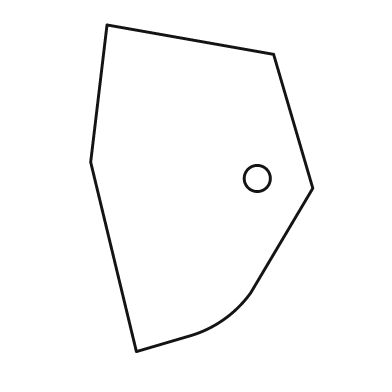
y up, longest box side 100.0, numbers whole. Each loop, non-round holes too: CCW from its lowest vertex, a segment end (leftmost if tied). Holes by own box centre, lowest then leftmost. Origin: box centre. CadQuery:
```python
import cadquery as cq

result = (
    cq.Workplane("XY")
    .moveTo(-20.0, -50.0)
    .lineTo(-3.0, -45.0)
    .threePointArc((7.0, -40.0), (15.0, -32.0))
    .lineTo(34.0, 0.0)
    .lineTo(22.0, 41.0)
    .lineTo(-29.0, 50.0)
    .lineTo(-34.0, 8.0)
    .close()
    .moveTo(17.0, 3.0)
    .circle(4.0)
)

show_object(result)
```